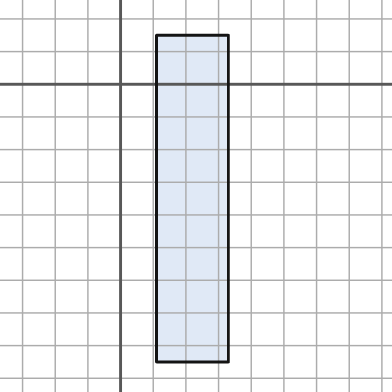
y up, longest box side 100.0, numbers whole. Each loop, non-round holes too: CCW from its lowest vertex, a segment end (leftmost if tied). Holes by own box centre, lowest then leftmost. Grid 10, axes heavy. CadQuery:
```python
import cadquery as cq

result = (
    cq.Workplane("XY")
    .moveTo(11.0, -85.0)
    .lineTo(33.0, -85.0)
    .lineTo(33.0, 15.0)
    .lineTo(11.0, 15.0)
    .close()
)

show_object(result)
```